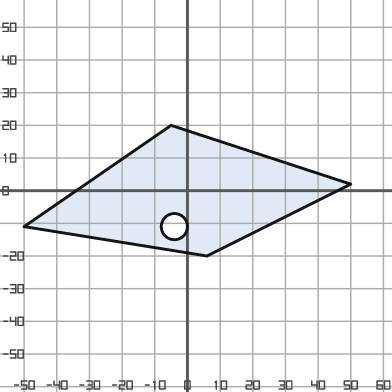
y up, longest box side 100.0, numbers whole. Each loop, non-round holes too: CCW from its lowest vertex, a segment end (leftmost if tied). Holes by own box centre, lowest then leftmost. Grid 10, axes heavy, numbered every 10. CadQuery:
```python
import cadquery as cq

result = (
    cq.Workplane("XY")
    .moveTo(6.0, -20.0)
    .lineTo(50.0, 2.0)
    .lineTo(-5.0, 20.0)
    .lineTo(-50.0, -11.0)
    .close()
    .moveTo(-4.0, -11.0)
    .circle(4.0)
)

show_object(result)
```